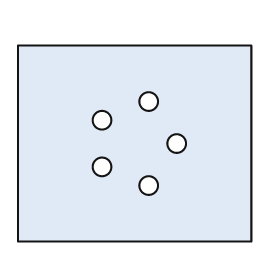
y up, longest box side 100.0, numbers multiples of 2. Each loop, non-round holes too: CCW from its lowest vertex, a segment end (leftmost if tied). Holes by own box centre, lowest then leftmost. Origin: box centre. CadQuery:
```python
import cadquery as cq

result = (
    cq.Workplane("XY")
    .moveTo(-50.0, -42.0)
    .lineTo(50.0, -42.0)
    .lineTo(50.0, 42.0)
    .lineTo(-50.0, 42.0)
    .close()
    .moveTo(6.0, -18.0)
    .circle(4.0)
    .moveTo(-14.0, -10.0)
    .circle(4.0)
    .moveTo(18.0, 0.0)
    .circle(4.0)
    .moveTo(-14.0, 10.0)
    .circle(4.0)
    .moveTo(6.0, 18.0)
    .circle(4.0)
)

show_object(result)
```